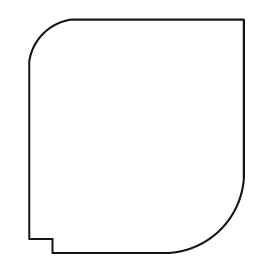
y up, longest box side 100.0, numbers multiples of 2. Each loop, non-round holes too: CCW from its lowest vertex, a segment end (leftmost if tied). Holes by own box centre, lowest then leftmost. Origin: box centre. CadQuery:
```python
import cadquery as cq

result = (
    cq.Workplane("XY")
    .moveTo(-36.0, -50.0)
    .lineTo(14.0, -50.0)
    .threePointArc((36.0, -40.0), (46.0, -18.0))
    .lineTo(46.0, 50.0)
    .lineTo(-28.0, 50.0)
    .threePointArc((-40.0, 44.0), (-46.0, 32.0))
    .lineTo(-46.0, -44.0)
    .lineTo(-36.0, -44.0)
    .close()
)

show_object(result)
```